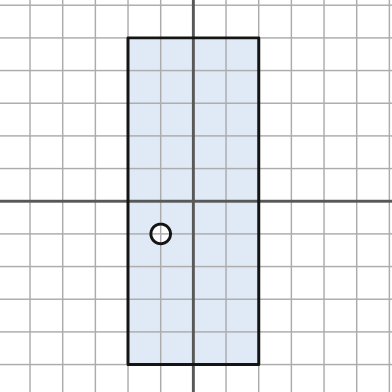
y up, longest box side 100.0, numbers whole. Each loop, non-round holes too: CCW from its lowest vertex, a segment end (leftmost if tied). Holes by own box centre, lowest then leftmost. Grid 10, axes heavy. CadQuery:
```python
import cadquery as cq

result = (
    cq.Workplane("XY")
    .moveTo(-20.0, -50.0)
    .lineTo(20.0, -50.0)
    .lineTo(20.0, 50.0)
    .lineTo(-20.0, 50.0)
    .close()
    .moveTo(-10.0, -10.0)
    .circle(3.0)
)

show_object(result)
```